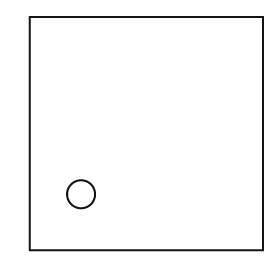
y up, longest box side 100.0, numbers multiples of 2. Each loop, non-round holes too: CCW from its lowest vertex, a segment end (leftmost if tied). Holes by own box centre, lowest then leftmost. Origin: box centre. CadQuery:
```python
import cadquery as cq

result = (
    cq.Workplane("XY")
    .moveTo(-50.0, -50.0)
    .lineTo(50.0, -50.0)
    .lineTo(50.0, 50.0)
    .lineTo(-50.0, 50.0)
    .close()
    .moveTo(-28.0, -26.0)
    .circle(6.0)
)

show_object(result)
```